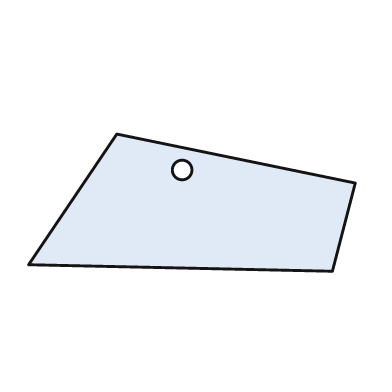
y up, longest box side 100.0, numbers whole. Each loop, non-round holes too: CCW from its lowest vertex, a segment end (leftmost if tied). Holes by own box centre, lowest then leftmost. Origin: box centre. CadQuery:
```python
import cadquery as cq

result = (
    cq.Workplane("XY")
    .moveTo(43.0, -21.0)
    .lineTo(50.0, 6.0)
    .lineTo(-23.0, 21.0)
    .lineTo(-50.0, -19.0)
    .close()
    .moveTo(-3.0, 10.0)
    .circle(3.0)
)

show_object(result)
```